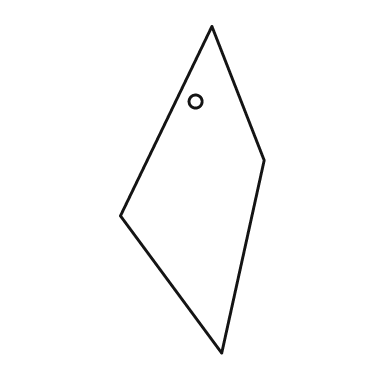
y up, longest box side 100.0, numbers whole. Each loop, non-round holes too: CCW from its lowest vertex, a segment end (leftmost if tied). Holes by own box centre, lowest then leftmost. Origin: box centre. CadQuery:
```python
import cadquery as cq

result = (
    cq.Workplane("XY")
    .moveTo(9.0, -50.0)
    .lineTo(22.0, 9.0)
    .lineTo(6.0, 50.0)
    .lineTo(-22.0, -8.0)
    .close()
    .moveTo(1.0, 27.0)
    .circle(2.0)
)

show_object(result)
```